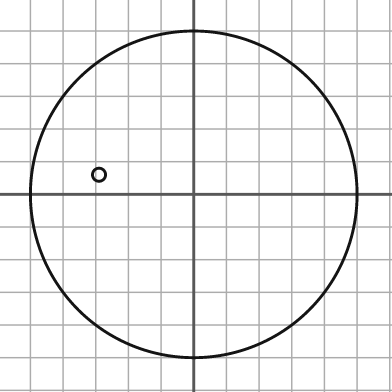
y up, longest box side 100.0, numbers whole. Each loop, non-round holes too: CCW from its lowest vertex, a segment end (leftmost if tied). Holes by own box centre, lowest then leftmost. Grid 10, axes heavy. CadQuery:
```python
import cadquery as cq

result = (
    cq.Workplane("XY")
    .moveTo(0.0, 0.0)
    .circle(50.0)
    .moveTo(-29.0, 6.0)
    .circle(2.0)
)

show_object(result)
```